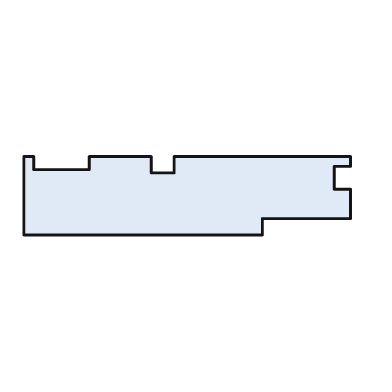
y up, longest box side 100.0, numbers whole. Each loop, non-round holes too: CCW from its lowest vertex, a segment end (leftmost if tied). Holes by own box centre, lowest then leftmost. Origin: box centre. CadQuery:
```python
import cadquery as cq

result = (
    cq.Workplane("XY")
    .moveTo(-50.0, -12.0)
    .lineTo(23.0, -12.0)
    .lineTo(23.0, -7.0)
    .lineTo(50.0, -7.0)
    .lineTo(50.0, 2.0)
    .lineTo(45.0, 2.0)
    .lineTo(45.0, 9.0)
    .lineTo(50.0, 9.0)
    .lineTo(50.0, 12.0)
    .lineTo(-4.0, 12.0)
    .lineTo(-4.0, 7.0)
    .lineTo(-11.0, 7.0)
    .lineTo(-11.0, 12.0)
    .lineTo(-30.0, 12.0)
    .lineTo(-30.0, 8.0)
    .lineTo(-47.0, 8.0)
    .lineTo(-47.0, 12.0)
    .lineTo(-50.0, 12.0)
    .close()
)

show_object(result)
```